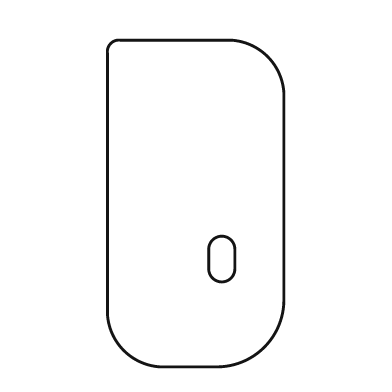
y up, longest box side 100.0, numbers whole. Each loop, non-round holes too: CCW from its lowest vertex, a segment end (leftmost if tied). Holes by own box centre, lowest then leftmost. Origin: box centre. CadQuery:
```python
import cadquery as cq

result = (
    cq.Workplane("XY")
    .moveTo(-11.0, -50.0)
    .lineTo(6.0, -50.0)
    .threePointArc((21.0, -44.0), (27.0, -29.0))
    .lineTo(27.0, 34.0)
    .threePointArc((22.0, 45.0), (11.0, 50.0))
    .lineTo(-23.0, 50.0)
    .threePointArc((-26.0, 49.0), (-27.0, 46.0))
    .lineTo(-27.0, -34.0)
    .threePointArc((-22.0, -45.0), (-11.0, -50.0))
    .close()
    .moveTo(4.0, -20.0)
    .threePointArc((8.0, -24.0), (12.0, -20.0))
    .lineTo(12.0, -14.0)
    .threePointArc((8.0, -10.0), (4.0, -14.0))
    .close()
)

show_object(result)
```